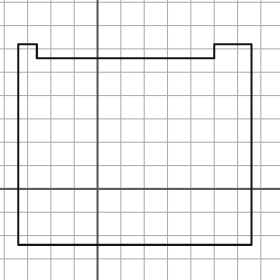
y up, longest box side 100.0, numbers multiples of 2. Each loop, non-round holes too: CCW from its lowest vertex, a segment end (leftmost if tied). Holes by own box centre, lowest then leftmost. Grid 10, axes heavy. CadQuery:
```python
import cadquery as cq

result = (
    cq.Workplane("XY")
    .moveTo(-34.0, -24.0)
    .lineTo(66.0, -24.0)
    .lineTo(66.0, 62.0)
    .lineTo(50.0, 62.0)
    .lineTo(50.0, 56.0)
    .lineTo(-26.0, 56.0)
    .lineTo(-26.0, 62.0)
    .lineTo(-34.0, 62.0)
    .close()
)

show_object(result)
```